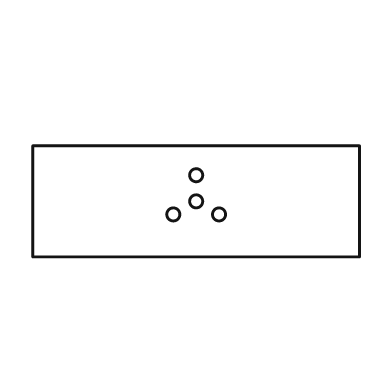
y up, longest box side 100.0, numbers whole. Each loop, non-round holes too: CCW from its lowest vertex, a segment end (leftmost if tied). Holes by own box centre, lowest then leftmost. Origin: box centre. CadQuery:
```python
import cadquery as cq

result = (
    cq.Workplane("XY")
    .moveTo(-50.0, -17.0)
    .lineTo(50.0, -17.0)
    .lineTo(50.0, 17.0)
    .lineTo(-50.0, 17.0)
    .close()
    .moveTo(-7.0, -4.0)
    .circle(2.0)
    .moveTo(7.0, -4.0)
    .circle(2.0)
    .moveTo(0.0, 0.0)
    .circle(2.0)
    .moveTo(0.0, 8.0)
    .circle(2.0)
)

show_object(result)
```